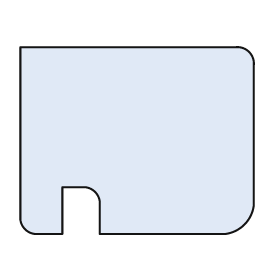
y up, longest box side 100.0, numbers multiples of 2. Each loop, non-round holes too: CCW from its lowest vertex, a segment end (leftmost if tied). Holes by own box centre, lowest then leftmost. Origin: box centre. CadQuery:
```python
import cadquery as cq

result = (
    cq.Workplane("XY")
    .moveTo(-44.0, -40.0)
    .lineTo(-32.0, -40.0)
    .lineTo(-32.0, -20.0)
    .lineTo(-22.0, -20.0)
    .threePointArc((-18.0, -22.0), (-16.0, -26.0))
    .lineTo(-16.0, -40.0)
    .lineTo(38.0, -40.0)
    .threePointArc((46.0, -36.0), (50.0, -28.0))
    .lineTo(50.0, 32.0)
    .threePointArc((48.0, 38.0), (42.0, 40.0))
    .lineTo(-50.0, 40.0)
    .lineTo(-50.0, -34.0)
    .threePointArc((-48.0, -38.0), (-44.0, -40.0))
    .close()
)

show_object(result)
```